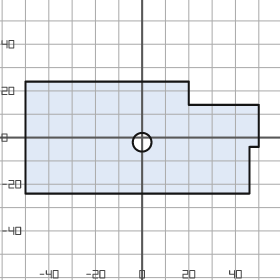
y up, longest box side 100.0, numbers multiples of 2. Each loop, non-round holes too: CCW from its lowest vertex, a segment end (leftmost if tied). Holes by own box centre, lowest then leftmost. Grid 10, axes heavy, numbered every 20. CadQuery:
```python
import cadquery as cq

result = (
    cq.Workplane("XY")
    .moveTo(-50.0, -24.0)
    .lineTo(46.0, -24.0)
    .lineTo(46.0, -4.0)
    .lineTo(50.0, -4.0)
    .lineTo(50.0, 14.0)
    .lineTo(20.0, 14.0)
    .lineTo(20.0, 24.0)
    .lineTo(-50.0, 24.0)
    .close()
    .moveTo(0.0, -2.0)
    .circle(4.0)
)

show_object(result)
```